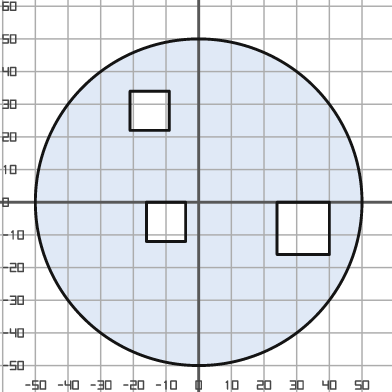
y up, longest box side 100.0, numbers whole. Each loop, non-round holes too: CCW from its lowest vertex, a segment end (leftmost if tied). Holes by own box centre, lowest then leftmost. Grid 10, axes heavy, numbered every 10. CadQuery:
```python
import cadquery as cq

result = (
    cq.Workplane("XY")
    .moveTo(0.0, 0.0)
    .circle(50.0)
    .moveTo(24.0, -16.0)
    .lineTo(40.0, -16.0)
    .lineTo(40.0, 0.0)
    .lineTo(24.0, 0.0)
    .close()
    .moveTo(-16.0, -12.0)
    .lineTo(-4.0, -12.0)
    .lineTo(-4.0, 0.0)
    .lineTo(-16.0, 0.0)
    .close()
    .moveTo(-21.0, 22.0)
    .lineTo(-9.0, 22.0)
    .lineTo(-9.0, 34.0)
    .lineTo(-21.0, 34.0)
    .close()
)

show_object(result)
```